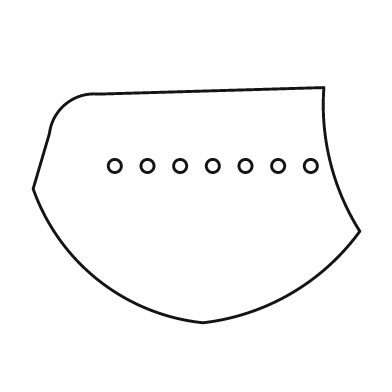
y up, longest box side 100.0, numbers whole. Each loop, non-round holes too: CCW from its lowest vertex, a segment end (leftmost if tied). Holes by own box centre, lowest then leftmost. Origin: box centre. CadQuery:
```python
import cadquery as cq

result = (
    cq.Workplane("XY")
    .moveTo(2.0, -36.0)
    .threePointArc((29.0, -27.0), (50.0, -8.0))
    .threePointArc((41.0, 13.0), (39.0, 36.0))
    .lineTo(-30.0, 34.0)
    .threePointArc((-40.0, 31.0), (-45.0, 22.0))
    .lineTo(-50.0, 5.0)
    .threePointArc((-30.0, -23.0), (2.0, -36.0))
    .close()
    .moveTo(-25.0, 12.0)
    .circle(2.0)
    .moveTo(-15.0, 12.0)
    .circle(2.0)
    .moveTo(-5.0, 12.0)
    .circle(2.0)
    .moveTo(5.0, 12.0)
    .circle(2.0)
    .moveTo(15.0, 12.0)
    .circle(2.0)
    .moveTo(25.0, 12.0)
    .circle(2.0)
    .moveTo(35.0, 12.0)
    .circle(2.0)
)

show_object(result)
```